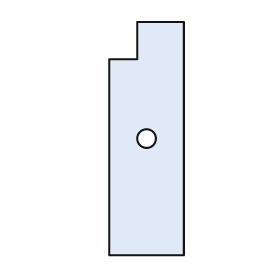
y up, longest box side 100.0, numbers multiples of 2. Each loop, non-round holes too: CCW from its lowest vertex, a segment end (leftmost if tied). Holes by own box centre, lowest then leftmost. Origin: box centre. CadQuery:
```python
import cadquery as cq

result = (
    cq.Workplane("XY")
    .moveTo(-16.0, -50.0)
    .lineTo(16.0, -50.0)
    .lineTo(16.0, 50.0)
    .lineTo(-4.0, 50.0)
    .lineTo(-4.0, 34.0)
    .lineTo(-16.0, 34.0)
    .close()
    .moveTo(0.0, 0.0)
    .circle(4.0)
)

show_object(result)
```